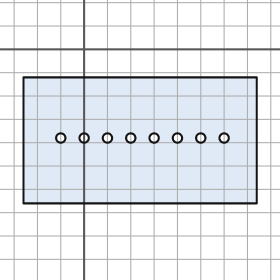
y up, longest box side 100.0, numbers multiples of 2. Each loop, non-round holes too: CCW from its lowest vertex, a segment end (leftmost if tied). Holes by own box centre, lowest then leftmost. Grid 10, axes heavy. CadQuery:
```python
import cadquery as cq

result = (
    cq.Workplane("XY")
    .moveTo(-26.0, -66.0)
    .lineTo(74.0, -66.0)
    .lineTo(74.0, -12.0)
    .lineTo(-26.0, -12.0)
    .close()
    .moveTo(-10.0, -38.0)
    .circle(2.0)
    .moveTo(0.0, -38.0)
    .circle(2.0)
    .moveTo(10.0, -38.0)
    .circle(2.0)
    .moveTo(20.0, -38.0)
    .circle(2.0)
    .moveTo(30.0, -38.0)
    .circle(2.0)
    .moveTo(40.0, -38.0)
    .circle(2.0)
    .moveTo(50.0, -38.0)
    .circle(2.0)
    .moveTo(60.0, -38.0)
    .circle(2.0)
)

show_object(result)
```